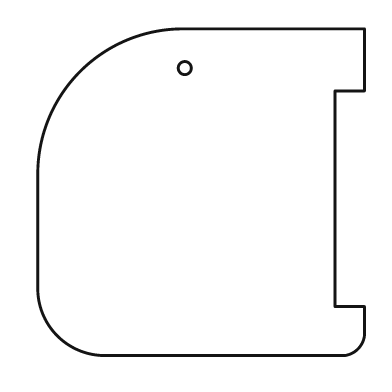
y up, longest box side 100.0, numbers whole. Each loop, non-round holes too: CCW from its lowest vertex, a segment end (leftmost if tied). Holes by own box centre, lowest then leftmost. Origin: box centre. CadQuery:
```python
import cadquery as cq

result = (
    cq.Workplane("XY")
    .moveTo(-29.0, -50.0)
    .lineTo(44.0, -50.0)
    .threePointArc((48.0, -48.0), (50.0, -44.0))
    .lineTo(50.0, -35.0)
    .lineTo(41.0, -35.0)
    .lineTo(41.0, 31.0)
    .lineTo(50.0, 31.0)
    .lineTo(50.0, 50.0)
    .lineTo(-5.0, 50.0)
    .threePointArc((-37.0, 37.0), (-50.0, 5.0))
    .lineTo(-50.0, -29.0)
    .threePointArc((-44.0, -44.0), (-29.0, -50.0))
    .close()
    .moveTo(-5.0, 38.0)
    .circle(2.0)
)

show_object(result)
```